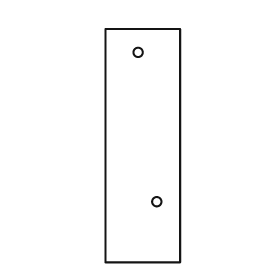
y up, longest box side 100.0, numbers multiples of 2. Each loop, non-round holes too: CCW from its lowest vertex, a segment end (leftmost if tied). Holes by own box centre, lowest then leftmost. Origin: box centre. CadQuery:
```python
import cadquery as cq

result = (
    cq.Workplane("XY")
    .moveTo(-16.0, -50.0)
    .lineTo(16.0, -50.0)
    .lineTo(16.0, 50.0)
    .lineTo(-16.0, 50.0)
    .close()
    .moveTo(6.0, -24.0)
    .circle(2.0)
    .moveTo(-2.0, 40.0)
    .circle(2.0)
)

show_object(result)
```